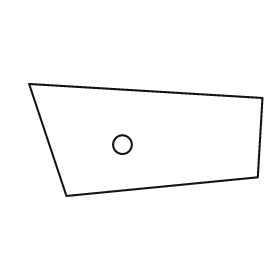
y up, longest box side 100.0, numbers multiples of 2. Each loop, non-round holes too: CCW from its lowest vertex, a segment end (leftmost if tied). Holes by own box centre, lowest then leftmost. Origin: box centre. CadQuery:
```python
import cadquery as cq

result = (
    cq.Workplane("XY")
    .moveTo(-34.0, -24.0)
    .lineTo(48.0, -16.0)
    .lineTo(50.0, 18.0)
    .lineTo(-50.0, 24.0)
    .close()
    .moveTo(-10.0, -2.0)
    .circle(4.0)
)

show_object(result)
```